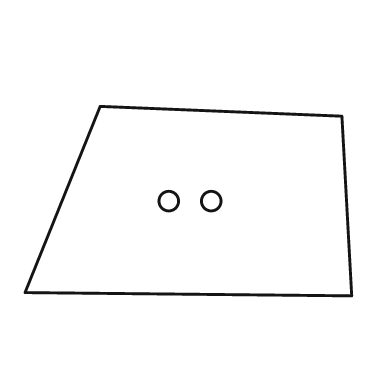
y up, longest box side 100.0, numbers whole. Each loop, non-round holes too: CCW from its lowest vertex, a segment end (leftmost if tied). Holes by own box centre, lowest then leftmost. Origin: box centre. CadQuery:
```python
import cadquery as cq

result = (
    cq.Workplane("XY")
    .moveTo(50.0, -29.0)
    .lineTo(47.0, 26.0)
    .lineTo(-27.0, 29.0)
    .lineTo(-50.0, -28.0)
    .close()
    .moveTo(-6.0, 0.0)
    .circle(3.0)
    .moveTo(7.0, 0.0)
    .circle(3.0)
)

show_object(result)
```